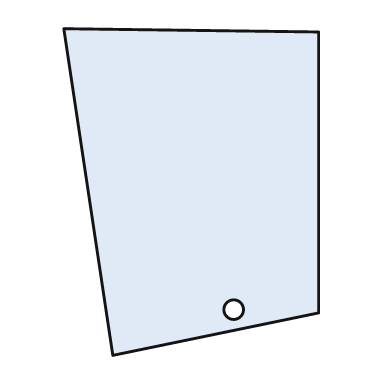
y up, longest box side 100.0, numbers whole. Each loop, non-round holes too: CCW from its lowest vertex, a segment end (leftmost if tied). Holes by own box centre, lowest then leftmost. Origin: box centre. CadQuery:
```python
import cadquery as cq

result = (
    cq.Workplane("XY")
    .moveTo(-24.0, -50.0)
    .lineTo(39.0, -37.0)
    .lineTo(39.0, 49.0)
    .lineTo(-39.0, 50.0)
    .close()
    .moveTo(13.0, -36.0)
    .circle(3.0)
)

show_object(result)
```